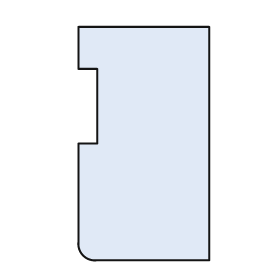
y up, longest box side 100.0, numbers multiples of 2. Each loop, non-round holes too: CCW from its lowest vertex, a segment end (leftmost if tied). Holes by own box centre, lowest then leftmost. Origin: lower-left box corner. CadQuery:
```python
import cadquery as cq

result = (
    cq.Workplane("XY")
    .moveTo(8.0, 0.0)
    .lineTo(56.0, 0.0)
    .lineTo(56.0, 100.0)
    .lineTo(0.0, 100.0)
    .lineTo(0.0, 82.0)
    .lineTo(8.0, 82.0)
    .lineTo(8.0, 50.0)
    .lineTo(0.0, 50.0)
    .lineTo(0.0, 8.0)
    .threePointArc((2.0, 2.0), (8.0, 0.0))
    .close()
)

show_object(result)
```